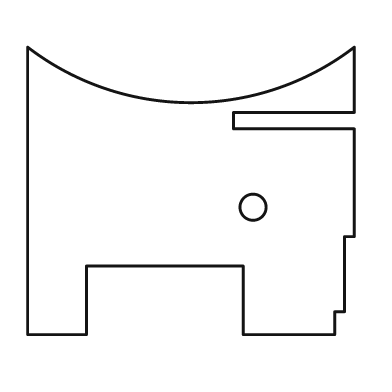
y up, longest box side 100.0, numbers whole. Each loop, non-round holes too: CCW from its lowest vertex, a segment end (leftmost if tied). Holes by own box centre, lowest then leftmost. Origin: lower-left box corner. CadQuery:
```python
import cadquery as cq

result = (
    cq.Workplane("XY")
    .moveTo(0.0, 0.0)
    .lineTo(18.0, 0.0)
    .lineTo(18.0, 21.0)
    .lineTo(66.0, 21.0)
    .lineTo(66.0, 0.0)
    .lineTo(94.0, 0.0)
    .lineTo(94.0, 7.0)
    .lineTo(97.0, 7.0)
    .lineTo(97.0, 30.0)
    .lineTo(100.0, 30.0)
    .lineTo(100.0, 63.0)
    .lineTo(63.0, 63.0)
    .lineTo(63.0, 68.0)
    .lineTo(100.0, 68.0)
    .lineTo(100.0, 88.0)
    .threePointArc((50.0, 71.0), (0.0, 88.0))
    .close()
    .moveTo(69.0, 39.0)
    .circle(4.0)
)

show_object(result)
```